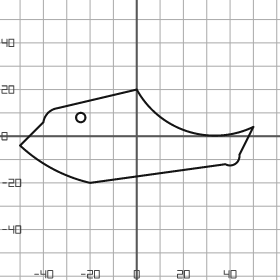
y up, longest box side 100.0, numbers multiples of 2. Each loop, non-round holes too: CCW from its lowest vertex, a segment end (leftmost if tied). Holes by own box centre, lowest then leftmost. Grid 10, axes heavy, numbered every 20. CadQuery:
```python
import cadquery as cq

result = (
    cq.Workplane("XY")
    .moveTo(-20.0, -20.0)
    .lineTo(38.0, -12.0)
    .threePointArc((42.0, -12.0), (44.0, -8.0))
    .lineTo(50.0, 4.0)
    .threePointArc((22.0, 2.0), (0.0, 20.0))
    .lineTo(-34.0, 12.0)
    .threePointArc((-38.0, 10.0), (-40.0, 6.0))
    .lineTo(-50.0, -4.0)
    .threePointArc((-36.0, -14.0), (-20.0, -20.0))
    .close()
    .moveTo(-24.0, 8.0)
    .circle(2.0)
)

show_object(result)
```